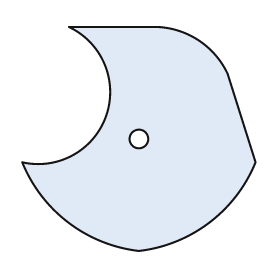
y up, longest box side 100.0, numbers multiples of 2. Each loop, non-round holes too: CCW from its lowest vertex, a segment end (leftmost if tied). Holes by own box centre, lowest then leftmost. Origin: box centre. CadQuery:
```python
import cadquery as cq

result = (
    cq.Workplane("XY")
    .moveTo(0.0, -48.0)
    .threePointArc((30.0, -36.0), (50.0, -10.0))
    .lineTo(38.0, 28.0)
    .threePointArc((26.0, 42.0), (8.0, 48.0))
    .lineTo(-30.0, 48.0)
    .threePointArc((-14.0, 10.0), (-50.0, -10.0))
    .threePointArc((-30.0, -36.0), (0.0, -48.0))
    .close()
    .moveTo(0.0, 0.0)
    .circle(4.0)
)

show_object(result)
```